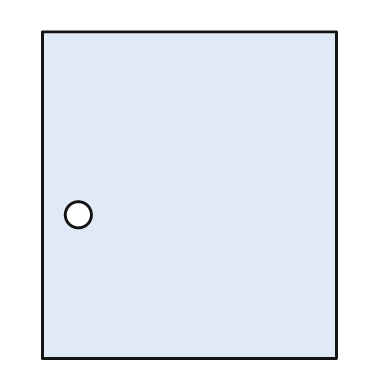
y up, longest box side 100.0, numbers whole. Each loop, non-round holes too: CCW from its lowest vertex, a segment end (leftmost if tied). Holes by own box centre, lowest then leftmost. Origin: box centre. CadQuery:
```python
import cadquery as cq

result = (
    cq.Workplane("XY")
    .moveTo(-45.0, -50.0)
    .lineTo(45.0, -50.0)
    .lineTo(45.0, 50.0)
    .lineTo(-45.0, 50.0)
    .close()
    .moveTo(-34.0, -6.0)
    .circle(4.0)
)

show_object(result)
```